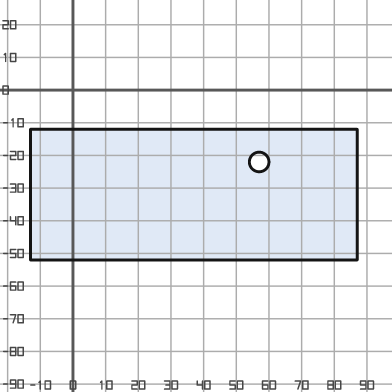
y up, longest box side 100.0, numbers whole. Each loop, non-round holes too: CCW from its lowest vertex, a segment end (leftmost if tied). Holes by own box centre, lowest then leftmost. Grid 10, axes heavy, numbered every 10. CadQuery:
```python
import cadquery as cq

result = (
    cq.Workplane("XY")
    .moveTo(-13.0, -52.0)
    .lineTo(87.0, -52.0)
    .lineTo(87.0, -12.0)
    .lineTo(-13.0, -12.0)
    .close()
    .moveTo(57.0, -22.0)
    .circle(3.0)
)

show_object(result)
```